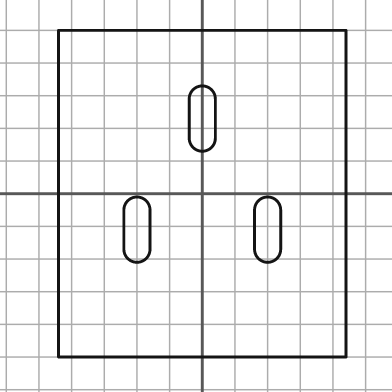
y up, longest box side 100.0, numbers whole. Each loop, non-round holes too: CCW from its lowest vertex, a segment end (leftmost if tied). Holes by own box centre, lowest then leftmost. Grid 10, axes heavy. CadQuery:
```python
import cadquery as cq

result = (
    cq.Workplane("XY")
    .moveTo(-44.0, -50.0)
    .lineTo(44.0, -50.0)
    .lineTo(44.0, 50.0)
    .lineTo(-44.0, 50.0)
    .close()
    .moveTo(-24.0, -17.0)
    .threePointArc((-20.0, -21.0), (-16.0, -17.0))
    .lineTo(-16.0, -5.0)
    .threePointArc((-20.0, -1.0), (-24.0, -5.0))
    .close()
    .moveTo(16.0, -17.0)
    .threePointArc((20.0, -21.0), (24.0, -17.0))
    .lineTo(24.0, -5.0)
    .threePointArc((20.0, -1.0), (16.0, -5.0))
    .close()
    .moveTo(-4.0, 17.0)
    .threePointArc((0.0, 13.0), (4.0, 17.0))
    .lineTo(4.0, 29.0)
    .threePointArc((0.0, 33.0), (-4.0, 29.0))
    .close()
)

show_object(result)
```